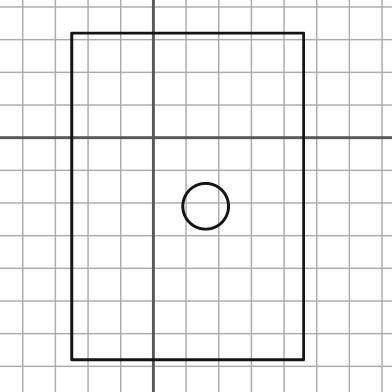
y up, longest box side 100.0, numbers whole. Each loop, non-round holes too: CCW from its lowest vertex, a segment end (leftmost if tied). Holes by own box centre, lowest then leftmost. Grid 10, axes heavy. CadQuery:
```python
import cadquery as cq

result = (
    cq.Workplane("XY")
    .moveTo(-25.0, -68.0)
    .lineTo(46.0, -68.0)
    .lineTo(46.0, 32.0)
    .lineTo(-25.0, 32.0)
    .close()
    .moveTo(16.0, -21.0)
    .circle(7.0)
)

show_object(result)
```